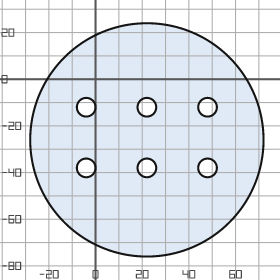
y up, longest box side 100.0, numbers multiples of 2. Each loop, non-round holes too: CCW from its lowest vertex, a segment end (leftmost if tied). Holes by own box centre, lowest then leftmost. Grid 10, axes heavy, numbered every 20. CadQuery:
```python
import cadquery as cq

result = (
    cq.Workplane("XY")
    .moveTo(22.0, -26.0)
    .circle(50.0)
    .moveTo(-4.0, -38.0)
    .circle(4.0)
    .moveTo(22.0, -38.0)
    .circle(4.0)
    .moveTo(48.0, -38.0)
    .circle(4.0)
    .moveTo(-4.0, -12.0)
    .circle(4.0)
    .moveTo(22.0, -12.0)
    .circle(4.0)
    .moveTo(48.0, -12.0)
    .circle(4.0)
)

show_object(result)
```